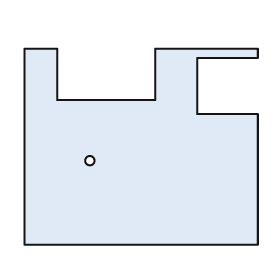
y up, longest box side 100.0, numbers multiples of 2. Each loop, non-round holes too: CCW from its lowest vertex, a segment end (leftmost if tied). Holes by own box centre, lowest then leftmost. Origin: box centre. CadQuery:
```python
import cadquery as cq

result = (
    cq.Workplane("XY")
    .moveTo(-50.0, -42.0)
    .lineTo(50.0, -42.0)
    .lineTo(50.0, 14.0)
    .lineTo(24.0, 14.0)
    .lineTo(24.0, 38.0)
    .lineTo(50.0, 38.0)
    .lineTo(50.0, 42.0)
    .lineTo(6.0, 42.0)
    .lineTo(6.0, 20.0)
    .lineTo(-36.0, 20.0)
    .lineTo(-36.0, 42.0)
    .lineTo(-50.0, 42.0)
    .close()
    .moveTo(-22.0, -6.0)
    .circle(2.0)
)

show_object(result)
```